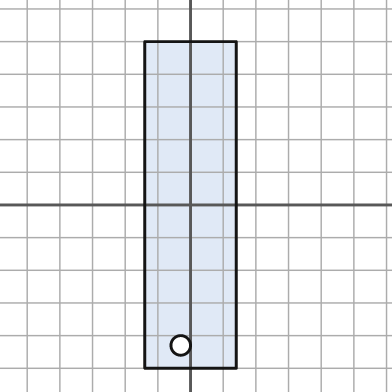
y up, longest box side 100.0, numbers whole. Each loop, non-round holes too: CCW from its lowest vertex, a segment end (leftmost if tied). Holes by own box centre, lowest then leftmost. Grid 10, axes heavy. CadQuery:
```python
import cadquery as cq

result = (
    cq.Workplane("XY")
    .moveTo(-14.0, -50.0)
    .lineTo(14.0, -50.0)
    .lineTo(14.0, 50.0)
    .lineTo(-14.0, 50.0)
    .close()
    .moveTo(-3.0, -43.0)
    .circle(3.0)
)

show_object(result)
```